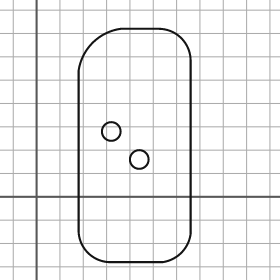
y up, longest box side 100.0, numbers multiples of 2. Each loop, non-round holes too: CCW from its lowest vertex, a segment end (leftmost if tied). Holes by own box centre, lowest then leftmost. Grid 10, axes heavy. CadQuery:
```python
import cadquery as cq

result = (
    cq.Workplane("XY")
    .moveTo(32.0, -28.0)
    .lineTo(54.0, -28.0)
    .threePointArc((62.0, -24.0), (66.0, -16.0))
    .lineTo(66.0, 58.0)
    .threePointArc((62.0, 68.0), (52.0, 72.0))
    .lineTo(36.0, 72.0)
    .threePointArc((24.0, 66.0), (18.0, 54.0))
    .lineTo(18.0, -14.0)
    .threePointArc((22.0, -24.0), (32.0, -28.0))
    .close()
    .moveTo(44.0, 16.0)
    .circle(4.0)
    .moveTo(32.0, 28.0)
    .circle(4.0)
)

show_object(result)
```